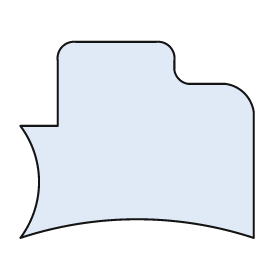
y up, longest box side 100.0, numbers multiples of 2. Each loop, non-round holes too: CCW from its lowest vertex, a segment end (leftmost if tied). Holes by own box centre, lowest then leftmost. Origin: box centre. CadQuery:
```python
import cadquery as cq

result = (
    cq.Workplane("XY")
    .moveTo(-50.0, -42.0)
    .threePointArc((0.0, -34.0), (50.0, -42.0))
    .lineTo(50.0, 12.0)
    .threePointArc((46.0, 20.0), (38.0, 24.0))
    .lineTo(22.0, 24.0)
    .threePointArc((18.0, 26.0), (16.0, 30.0))
    .lineTo(16.0, 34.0)
    .threePointArc((14.0, 40.0), (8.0, 42.0))
    .lineTo(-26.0, 42.0)
    .threePointArc((-32.0, 40.0), (-34.0, 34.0))
    .lineTo(-34.0, 6.0)
    .lineTo(-50.0, 6.0)
    .threePointArc((-42.0, -18.0), (-50.0, -42.0))
    .close()
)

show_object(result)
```